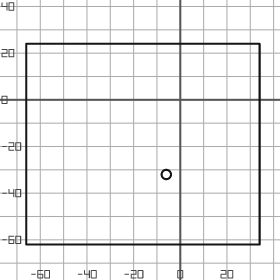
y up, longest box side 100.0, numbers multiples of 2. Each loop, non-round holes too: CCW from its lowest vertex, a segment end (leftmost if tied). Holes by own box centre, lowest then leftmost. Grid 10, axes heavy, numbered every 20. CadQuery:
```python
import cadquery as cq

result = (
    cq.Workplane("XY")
    .moveTo(-66.0, -62.0)
    .lineTo(34.0, -62.0)
    .lineTo(34.0, 24.0)
    .lineTo(-66.0, 24.0)
    .close()
    .moveTo(-6.0, -32.0)
    .circle(2.0)
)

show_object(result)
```